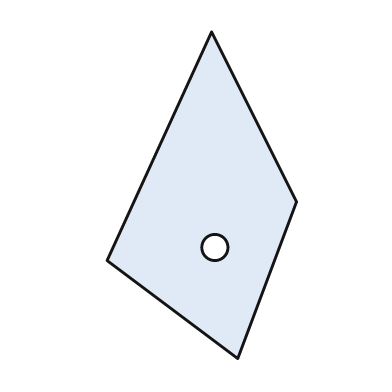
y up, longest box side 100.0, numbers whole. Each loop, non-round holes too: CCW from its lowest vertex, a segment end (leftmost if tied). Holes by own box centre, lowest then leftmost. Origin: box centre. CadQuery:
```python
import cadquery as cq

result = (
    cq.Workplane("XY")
    .moveTo(11.0, -50.0)
    .lineTo(29.0, -2.0)
    .lineTo(3.0, 50.0)
    .lineTo(-29.0, -20.0)
    .close()
    .moveTo(4.0, -16.0)
    .circle(4.0)
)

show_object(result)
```